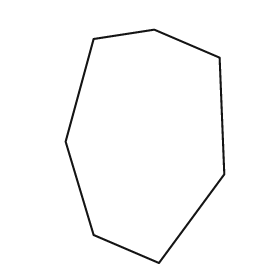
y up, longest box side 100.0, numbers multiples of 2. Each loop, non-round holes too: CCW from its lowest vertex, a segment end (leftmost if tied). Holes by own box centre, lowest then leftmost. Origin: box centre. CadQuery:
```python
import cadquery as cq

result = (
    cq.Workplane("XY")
    .moveTo(6.0, -50.0)
    .lineTo(34.0, -12.0)
    .lineTo(32.0, 38.0)
    .lineTo(4.0, 50.0)
    .lineTo(-22.0, 46.0)
    .lineTo(-34.0, 2.0)
    .lineTo(-22.0, -38.0)
    .close()
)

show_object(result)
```